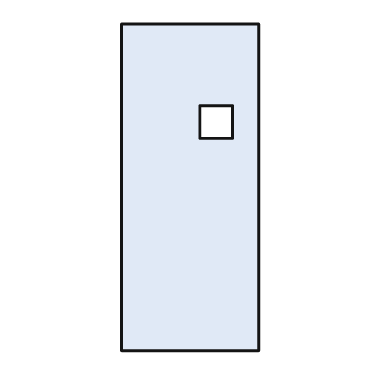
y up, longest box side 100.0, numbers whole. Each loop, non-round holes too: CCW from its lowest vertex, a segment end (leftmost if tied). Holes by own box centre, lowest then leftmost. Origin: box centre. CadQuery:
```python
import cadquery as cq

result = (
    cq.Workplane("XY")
    .moveTo(-21.0, -50.0)
    .lineTo(21.0, -50.0)
    .lineTo(21.0, 50.0)
    .lineTo(-21.0, 50.0)
    .close()
    .moveTo(3.0, 15.0)
    .lineTo(13.0, 15.0)
    .lineTo(13.0, 25.0)
    .lineTo(3.0, 25.0)
    .close()
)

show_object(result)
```